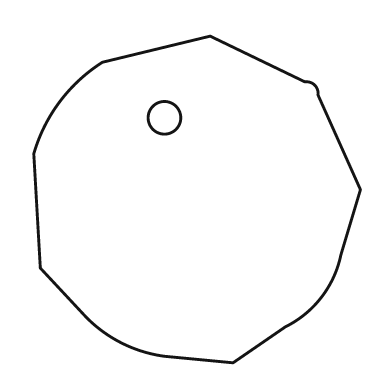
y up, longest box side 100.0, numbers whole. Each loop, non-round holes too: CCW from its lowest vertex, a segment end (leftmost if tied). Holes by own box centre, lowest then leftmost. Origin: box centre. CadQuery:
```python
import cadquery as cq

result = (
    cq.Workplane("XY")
    .moveTo(11.0, -50.0)
    .lineTo(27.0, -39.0)
    .threePointArc((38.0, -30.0), (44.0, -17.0))
    .lineTo(50.0, 3.0)
    .lineTo(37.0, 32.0)
    .threePointArc((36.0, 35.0), (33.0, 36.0))
    .lineTo(4.0, 50.0)
    .lineTo(-29.0, 42.0)
    .threePointArc((-42.0, 30.0), (-50.0, 14.0))
    .lineTo(-48.0, -21.0)
    .lineTo(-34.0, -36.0)
    .threePointArc((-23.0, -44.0), (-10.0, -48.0))
    .close()
    .moveTo(-10.0, 25.0)
    .circle(5.0)
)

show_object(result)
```